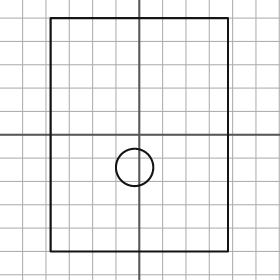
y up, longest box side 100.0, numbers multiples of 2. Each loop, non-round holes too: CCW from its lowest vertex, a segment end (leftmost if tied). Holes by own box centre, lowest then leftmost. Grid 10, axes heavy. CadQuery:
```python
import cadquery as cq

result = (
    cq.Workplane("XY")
    .moveTo(-38.0, -50.0)
    .lineTo(38.0, -50.0)
    .lineTo(38.0, 50.0)
    .lineTo(-38.0, 50.0)
    .close()
    .moveTo(-2.0, -14.0)
    .circle(8.0)
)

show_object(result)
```